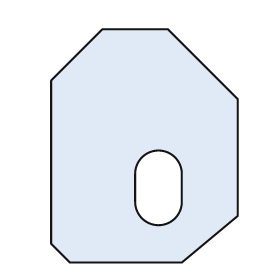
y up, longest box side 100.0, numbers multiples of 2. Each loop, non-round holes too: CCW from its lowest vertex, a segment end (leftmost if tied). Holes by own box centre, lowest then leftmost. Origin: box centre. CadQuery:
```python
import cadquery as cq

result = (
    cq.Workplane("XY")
    .moveTo(-32.0, -50.0)
    .lineTo(16.0, -50.0)
    .lineTo(40.0, -30.0)
    .lineTo(40.0, 20.0)
    .lineTo(10.0, 50.0)
    .lineTo(-18.0, 50.0)
    .lineTo(-40.0, 28.0)
    .lineTo(-40.0, -42.0)
    .close()
    .moveTo(-4.0, -24.0)
    .threePointArc((6.0, -34.0), (16.0, -24.0))
    .lineTo(16.0, -12.0)
    .threePointArc((6.0, -2.0), (-4.0, -12.0))
    .close()
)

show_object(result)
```